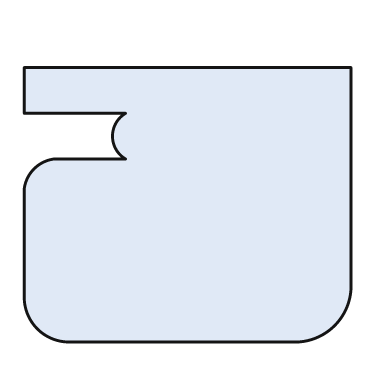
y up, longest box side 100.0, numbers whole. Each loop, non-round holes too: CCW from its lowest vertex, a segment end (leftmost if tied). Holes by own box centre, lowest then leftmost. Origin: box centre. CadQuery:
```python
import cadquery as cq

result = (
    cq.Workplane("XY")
    .moveTo(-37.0, -42.0)
    .lineTo(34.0, -42.0)
    .threePointArc((45.0, -37.0), (50.0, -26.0))
    .lineTo(50.0, 42.0)
    .lineTo(-50.0, 42.0)
    .lineTo(-50.0, 28.0)
    .lineTo(-19.0, 28.0)
    .threePointArc((-23.0, 21.0), (-19.0, 14.0))
    .lineTo(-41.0, 14.0)
    .threePointArc((-47.0, 11.0), (-50.0, 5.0))
    .lineTo(-50.0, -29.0)
    .threePointArc((-46.0, -38.0), (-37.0, -42.0))
    .close()
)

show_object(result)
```